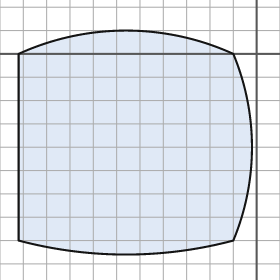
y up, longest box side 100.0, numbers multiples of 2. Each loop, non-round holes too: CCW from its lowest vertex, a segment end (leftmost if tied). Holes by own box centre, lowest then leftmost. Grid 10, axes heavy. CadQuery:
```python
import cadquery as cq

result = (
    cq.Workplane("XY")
    .moveTo(-102.0, -80.0)
    .threePointArc((-56.0, -86.0), (-10.0, -80.0))
    .threePointArc((-2.0, -40.0), (-10.0, 0.0))
    .threePointArc((-56.0, 10.0), (-102.0, 0.0))
    .close()
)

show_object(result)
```